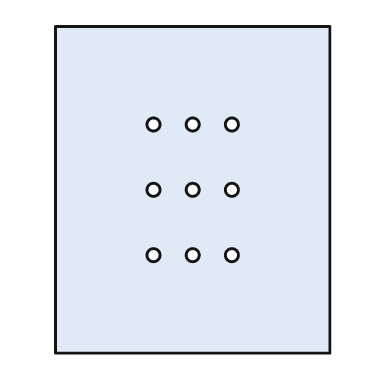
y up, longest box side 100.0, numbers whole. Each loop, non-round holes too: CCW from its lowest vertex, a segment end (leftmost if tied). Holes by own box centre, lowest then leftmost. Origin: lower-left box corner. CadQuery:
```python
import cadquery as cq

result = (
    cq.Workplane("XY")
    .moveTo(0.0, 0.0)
    .lineTo(84.0, 0.0)
    .lineTo(84.0, 100.0)
    .lineTo(0.0, 100.0)
    .close()
    .moveTo(30.0, 30.0)
    .circle(2.0)
    .moveTo(42.0, 30.0)
    .circle(2.0)
    .moveTo(54.0, 30.0)
    .circle(2.0)
    .moveTo(30.0, 50.0)
    .circle(2.0)
    .moveTo(42.0, 50.0)
    .circle(2.0)
    .moveTo(54.0, 50.0)
    .circle(2.0)
    .moveTo(30.0, 70.0)
    .circle(2.0)
    .moveTo(42.0, 70.0)
    .circle(2.0)
    .moveTo(54.0, 70.0)
    .circle(2.0)
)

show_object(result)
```